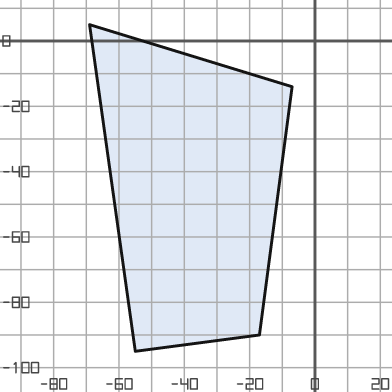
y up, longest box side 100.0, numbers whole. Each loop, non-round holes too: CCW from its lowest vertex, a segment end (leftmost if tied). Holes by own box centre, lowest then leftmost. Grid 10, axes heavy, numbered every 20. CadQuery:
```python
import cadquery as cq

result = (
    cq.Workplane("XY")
    .moveTo(-55.0, -95.0)
    .lineTo(-17.0, -90.0)
    .lineTo(-7.0, -14.0)
    .lineTo(-69.0, 5.0)
    .close()
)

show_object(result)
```